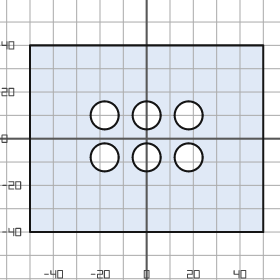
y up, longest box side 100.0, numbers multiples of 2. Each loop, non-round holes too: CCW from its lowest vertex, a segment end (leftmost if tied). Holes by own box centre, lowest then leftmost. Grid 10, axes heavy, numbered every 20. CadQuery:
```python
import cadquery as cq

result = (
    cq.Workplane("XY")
    .moveTo(-50.0, -40.0)
    .lineTo(50.0, -40.0)
    .lineTo(50.0, 40.0)
    .lineTo(-50.0, 40.0)
    .close()
    .moveTo(-18.0, -8.0)
    .circle(6.0)
    .moveTo(0.0, -8.0)
    .circle(6.0)
    .moveTo(18.0, -8.0)
    .circle(6.0)
    .moveTo(-18.0, 10.0)
    .circle(6.0)
    .moveTo(0.0, 10.0)
    .circle(6.0)
    .moveTo(18.0, 10.0)
    .circle(6.0)
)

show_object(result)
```